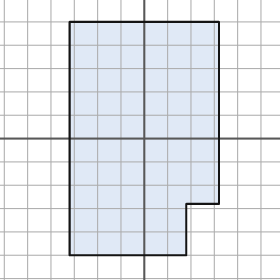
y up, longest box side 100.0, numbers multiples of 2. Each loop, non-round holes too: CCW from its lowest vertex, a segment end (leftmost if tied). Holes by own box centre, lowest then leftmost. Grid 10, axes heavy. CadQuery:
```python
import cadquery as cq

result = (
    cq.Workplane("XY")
    .moveTo(-32.0, -50.0)
    .lineTo(18.0, -50.0)
    .lineTo(18.0, -28.0)
    .lineTo(32.0, -28.0)
    .lineTo(32.0, 50.0)
    .lineTo(-32.0, 50.0)
    .close()
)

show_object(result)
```